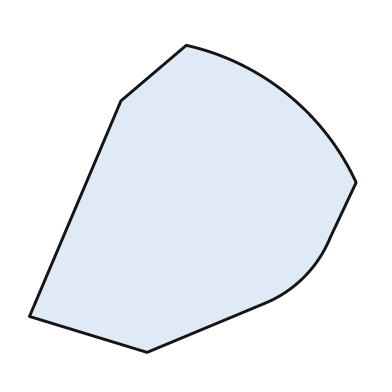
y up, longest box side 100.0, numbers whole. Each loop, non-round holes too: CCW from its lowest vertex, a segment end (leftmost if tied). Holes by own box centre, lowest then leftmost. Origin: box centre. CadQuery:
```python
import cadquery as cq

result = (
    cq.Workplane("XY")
    .moveTo(-14.0, -47.0)
    .lineTo(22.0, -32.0)
    .threePointArc((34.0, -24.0), (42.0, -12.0))
    .lineTo(50.0, 5.0)
    .threePointArc((29.0, 32.0), (-2.0, 47.0))
    .lineTo(-22.0, 30.0)
    .lineTo(-50.0, -36.0)
    .close()
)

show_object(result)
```